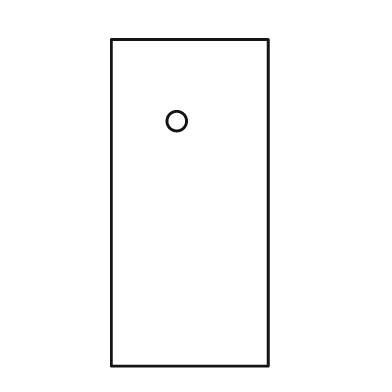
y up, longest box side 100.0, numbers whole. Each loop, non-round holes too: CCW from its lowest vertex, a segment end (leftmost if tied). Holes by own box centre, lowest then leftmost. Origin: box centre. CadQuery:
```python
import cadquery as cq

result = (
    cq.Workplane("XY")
    .moveTo(-24.0, -50.0)
    .lineTo(24.0, -50.0)
    .lineTo(24.0, 50.0)
    .lineTo(-24.0, 50.0)
    .close()
    .moveTo(-4.0, 25.0)
    .circle(3.0)
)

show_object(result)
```